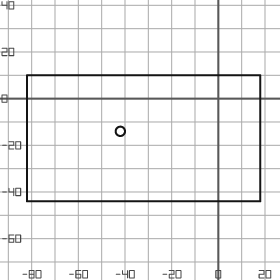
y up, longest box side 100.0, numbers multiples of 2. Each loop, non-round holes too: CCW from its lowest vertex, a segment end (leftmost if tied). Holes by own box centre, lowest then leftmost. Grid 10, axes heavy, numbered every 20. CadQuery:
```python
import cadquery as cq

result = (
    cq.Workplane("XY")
    .moveTo(-82.0, -44.0)
    .lineTo(18.0, -44.0)
    .lineTo(18.0, 10.0)
    .lineTo(-82.0, 10.0)
    .close()
    .moveTo(-42.0, -14.0)
    .circle(2.0)
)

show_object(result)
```